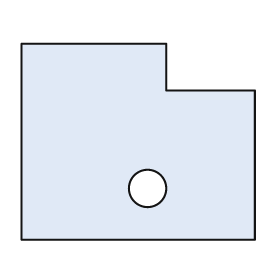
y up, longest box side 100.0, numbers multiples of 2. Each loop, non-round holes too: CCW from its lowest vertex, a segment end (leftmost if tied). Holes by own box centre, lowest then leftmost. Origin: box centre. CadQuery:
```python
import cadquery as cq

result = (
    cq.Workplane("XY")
    .moveTo(-50.0, -42.0)
    .lineTo(50.0, -42.0)
    .lineTo(50.0, 22.0)
    .lineTo(12.0, 22.0)
    .lineTo(12.0, 42.0)
    .lineTo(-50.0, 42.0)
    .close()
    .moveTo(4.0, -20.0)
    .circle(8.0)
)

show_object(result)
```